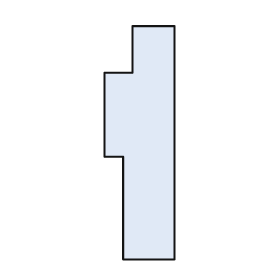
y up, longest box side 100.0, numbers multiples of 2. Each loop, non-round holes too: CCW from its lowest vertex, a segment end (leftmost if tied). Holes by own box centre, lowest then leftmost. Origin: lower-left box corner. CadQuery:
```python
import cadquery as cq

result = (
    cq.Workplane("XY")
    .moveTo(8.0, 0.0)
    .lineTo(30.0, 0.0)
    .lineTo(30.0, 100.0)
    .lineTo(12.0, 100.0)
    .lineTo(12.0, 80.0)
    .lineTo(0.0, 80.0)
    .lineTo(0.0, 44.0)
    .lineTo(8.0, 44.0)
    .close()
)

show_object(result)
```